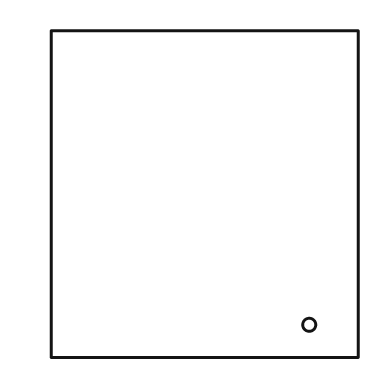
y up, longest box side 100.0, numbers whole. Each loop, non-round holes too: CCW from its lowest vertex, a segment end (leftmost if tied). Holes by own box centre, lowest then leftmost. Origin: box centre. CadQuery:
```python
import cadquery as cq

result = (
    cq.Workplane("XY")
    .moveTo(-47.0, -50.0)
    .lineTo(47.0, -50.0)
    .lineTo(47.0, 50.0)
    .lineTo(-47.0, 50.0)
    .close()
    .moveTo(32.0, -40.0)
    .circle(2.0)
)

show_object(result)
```